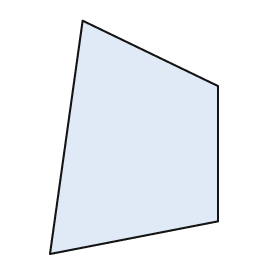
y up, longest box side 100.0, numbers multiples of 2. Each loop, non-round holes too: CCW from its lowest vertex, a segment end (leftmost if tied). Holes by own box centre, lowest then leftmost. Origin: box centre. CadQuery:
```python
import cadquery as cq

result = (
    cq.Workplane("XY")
    .moveTo(-36.0, -50.0)
    .lineTo(36.0, -36.0)
    .lineTo(36.0, 22.0)
    .lineTo(-22.0, 50.0)
    .close()
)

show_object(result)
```